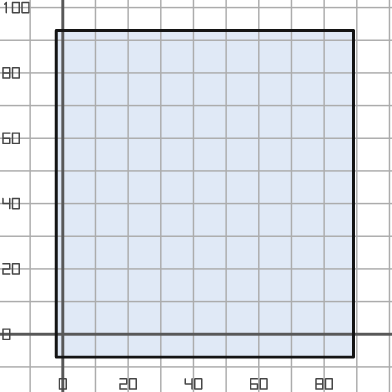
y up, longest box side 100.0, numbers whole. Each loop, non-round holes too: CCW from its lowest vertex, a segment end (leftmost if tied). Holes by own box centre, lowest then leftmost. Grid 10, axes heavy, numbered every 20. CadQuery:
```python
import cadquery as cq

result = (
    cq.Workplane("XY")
    .moveTo(-2.0, -7.0)
    .lineTo(89.0, -7.0)
    .lineTo(89.0, 93.0)
    .lineTo(-2.0, 93.0)
    .close()
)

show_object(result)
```